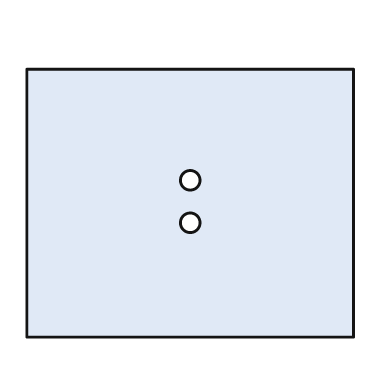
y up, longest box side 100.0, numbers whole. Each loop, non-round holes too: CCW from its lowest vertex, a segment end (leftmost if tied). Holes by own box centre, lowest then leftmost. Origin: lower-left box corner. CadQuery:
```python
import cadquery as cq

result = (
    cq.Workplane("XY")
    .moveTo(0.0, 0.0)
    .lineTo(100.0, 0.0)
    .lineTo(100.0, 82.0)
    .lineTo(0.0, 82.0)
    .close()
    .moveTo(50.0, 35.0)
    .circle(3.0)
    .moveTo(50.0, 48.0)
    .circle(3.0)
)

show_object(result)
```